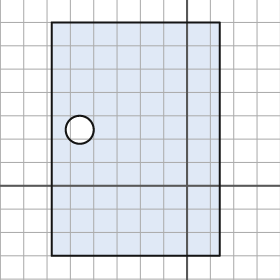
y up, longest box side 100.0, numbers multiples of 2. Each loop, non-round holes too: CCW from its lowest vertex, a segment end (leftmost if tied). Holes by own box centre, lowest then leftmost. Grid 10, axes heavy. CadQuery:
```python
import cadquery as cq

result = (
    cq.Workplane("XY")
    .moveTo(-58.0, -30.0)
    .lineTo(14.0, -30.0)
    .lineTo(14.0, 70.0)
    .lineTo(-58.0, 70.0)
    .close()
    .moveTo(-46.0, 24.0)
    .circle(6.0)
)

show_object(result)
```